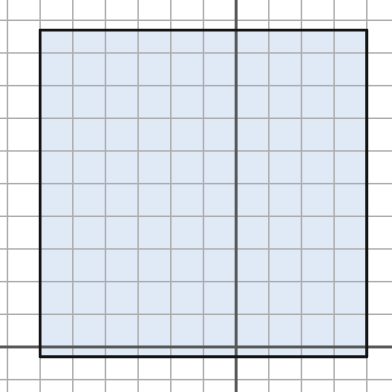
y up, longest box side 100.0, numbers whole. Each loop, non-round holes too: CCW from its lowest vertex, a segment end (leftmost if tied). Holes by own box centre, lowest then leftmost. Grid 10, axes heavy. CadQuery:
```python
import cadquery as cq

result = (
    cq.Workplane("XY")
    .moveTo(-60.0, -3.0)
    .lineTo(40.0, -3.0)
    .lineTo(40.0, 97.0)
    .lineTo(-60.0, 97.0)
    .close()
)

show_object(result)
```